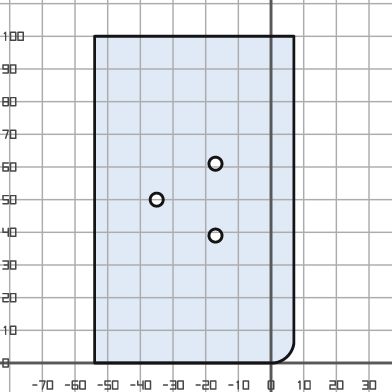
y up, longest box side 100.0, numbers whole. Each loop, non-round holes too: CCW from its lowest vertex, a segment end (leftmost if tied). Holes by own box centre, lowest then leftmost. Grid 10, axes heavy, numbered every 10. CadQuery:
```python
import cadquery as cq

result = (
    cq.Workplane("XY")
    .moveTo(-54.0, 0.0)
    .lineTo(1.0, 0.0)
    .threePointArc((5.0, 2.0), (7.0, 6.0))
    .lineTo(7.0, 100.0)
    .lineTo(-54.0, 100.0)
    .close()
    .moveTo(-17.0, 39.0)
    .circle(2.0)
    .moveTo(-35.0, 50.0)
    .circle(2.0)
    .moveTo(-17.0, 61.0)
    .circle(2.0)
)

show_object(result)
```